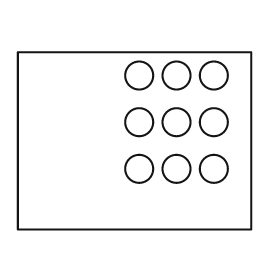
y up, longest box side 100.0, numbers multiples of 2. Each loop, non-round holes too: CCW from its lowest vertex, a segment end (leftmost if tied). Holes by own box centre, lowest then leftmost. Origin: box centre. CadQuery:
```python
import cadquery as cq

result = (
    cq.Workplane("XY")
    .moveTo(-50.0, -38.0)
    .lineTo(50.0, -38.0)
    .lineTo(50.0, 38.0)
    .lineTo(-50.0, 38.0)
    .close()
    .moveTo(2.0, -12.0)
    .circle(6.0)
    .moveTo(18.0, -12.0)
    .circle(6.0)
    .moveTo(34.0, -12.0)
    .circle(6.0)
    .moveTo(2.0, 8.0)
    .circle(6.0)
    .moveTo(18.0, 8.0)
    .circle(6.0)
    .moveTo(34.0, 8.0)
    .circle(6.0)
    .moveTo(2.0, 28.0)
    .circle(6.0)
    .moveTo(18.0, 28.0)
    .circle(6.0)
    .moveTo(34.0, 28.0)
    .circle(6.0)
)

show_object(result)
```